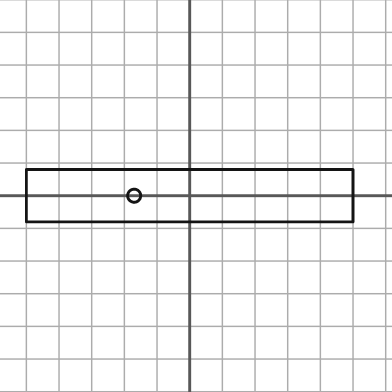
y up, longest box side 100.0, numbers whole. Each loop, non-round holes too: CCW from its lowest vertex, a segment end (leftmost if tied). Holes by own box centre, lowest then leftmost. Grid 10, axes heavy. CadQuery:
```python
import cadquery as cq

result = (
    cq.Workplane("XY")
    .moveTo(-50.0, -8.0)
    .lineTo(50.0, -8.0)
    .lineTo(50.0, 8.0)
    .lineTo(-50.0, 8.0)
    .close()
    .moveTo(-17.0, 0.0)
    .circle(2.0)
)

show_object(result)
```